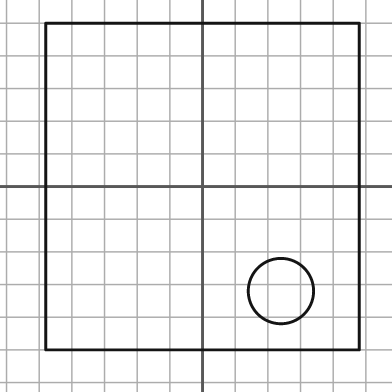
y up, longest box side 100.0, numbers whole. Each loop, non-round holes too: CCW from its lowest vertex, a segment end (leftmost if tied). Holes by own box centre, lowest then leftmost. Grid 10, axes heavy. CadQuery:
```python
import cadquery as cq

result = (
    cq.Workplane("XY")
    .moveTo(-48.0, -50.0)
    .lineTo(48.0, -50.0)
    .lineTo(48.0, 50.0)
    .lineTo(-48.0, 50.0)
    .close()
    .moveTo(24.0, -32.0)
    .circle(10.0)
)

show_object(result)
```